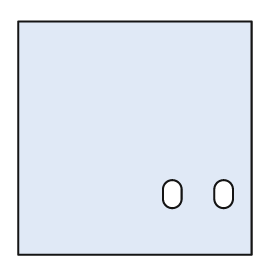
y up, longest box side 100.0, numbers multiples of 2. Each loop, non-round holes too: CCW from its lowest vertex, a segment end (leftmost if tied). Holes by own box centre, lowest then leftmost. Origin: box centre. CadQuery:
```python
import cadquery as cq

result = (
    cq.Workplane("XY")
    .moveTo(-50.0, -50.0)
    .lineTo(50.0, -50.0)
    .lineTo(50.0, 50.0)
    .lineTo(-50.0, 50.0)
    .close()
    .moveTo(12.0, -26.0)
    .threePointArc((16.0, -30.0), (20.0, -26.0))
    .lineTo(20.0, -22.0)
    .threePointArc((16.0, -18.0), (12.0, -22.0))
    .close()
    .moveTo(34.0, -26.0)
    .threePointArc((38.0, -30.0), (42.0, -26.0))
    .lineTo(42.0, -22.0)
    .threePointArc((38.0, -18.0), (34.0, -22.0))
    .close()
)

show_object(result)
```